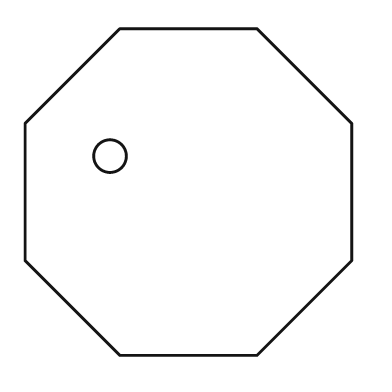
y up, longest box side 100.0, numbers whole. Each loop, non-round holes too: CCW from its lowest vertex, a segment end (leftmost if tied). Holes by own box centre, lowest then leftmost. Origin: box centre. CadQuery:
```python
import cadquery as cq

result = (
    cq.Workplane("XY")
    .moveTo(-21.0, -50.0)
    .lineTo(21.0, -50.0)
    .lineTo(50.0, -21.0)
    .lineTo(50.0, 21.0)
    .lineTo(21.0, 50.0)
    .lineTo(-21.0, 50.0)
    .lineTo(-50.0, 21.0)
    .lineTo(-50.0, -21.0)
    .close()
    .moveTo(-24.0, 11.0)
    .circle(5.0)
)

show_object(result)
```